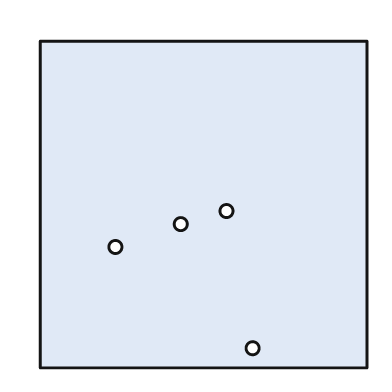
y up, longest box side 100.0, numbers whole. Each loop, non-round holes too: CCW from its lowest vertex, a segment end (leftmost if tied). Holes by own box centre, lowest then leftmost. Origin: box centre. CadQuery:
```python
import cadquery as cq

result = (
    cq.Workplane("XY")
    .moveTo(-50.0, -50.0)
    .lineTo(50.0, -50.0)
    .lineTo(50.0, 50.0)
    .lineTo(-50.0, 50.0)
    .close()
    .moveTo(15.0, -44.0)
    .circle(2.0)
    .moveTo(-27.0, -13.0)
    .circle(2.0)
    .moveTo(-7.0, -6.0)
    .circle(2.0)
    .moveTo(7.0, -2.0)
    .circle(2.0)
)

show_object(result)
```